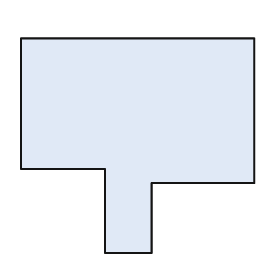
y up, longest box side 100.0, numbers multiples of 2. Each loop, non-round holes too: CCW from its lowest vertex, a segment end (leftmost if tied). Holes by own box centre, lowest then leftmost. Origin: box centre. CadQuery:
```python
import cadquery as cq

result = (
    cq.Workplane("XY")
    .moveTo(-14.0, -46.0)
    .lineTo(6.0, -46.0)
    .lineTo(6.0, -16.0)
    .lineTo(50.0, -16.0)
    .lineTo(50.0, 46.0)
    .lineTo(-50.0, 46.0)
    .lineTo(-50.0, -10.0)
    .lineTo(-14.0, -10.0)
    .close()
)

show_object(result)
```